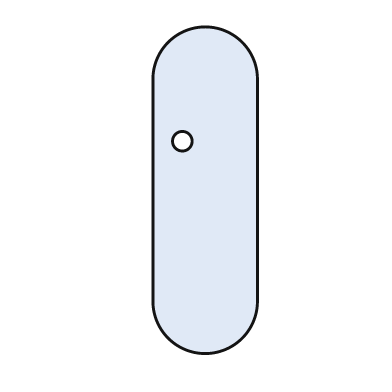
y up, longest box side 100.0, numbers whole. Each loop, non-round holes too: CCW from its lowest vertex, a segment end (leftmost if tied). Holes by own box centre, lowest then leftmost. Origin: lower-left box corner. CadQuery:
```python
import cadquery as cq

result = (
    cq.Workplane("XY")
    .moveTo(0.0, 16.0)
    .threePointArc((16.0, 0.0), (32.0, 16.0))
    .lineTo(32.0, 84.0)
    .threePointArc((16.0, 100.0), (0.0, 84.0))
    .close()
    .moveTo(9.0, 65.0)
    .circle(3.0)
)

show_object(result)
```